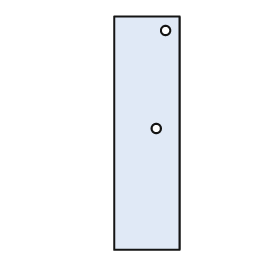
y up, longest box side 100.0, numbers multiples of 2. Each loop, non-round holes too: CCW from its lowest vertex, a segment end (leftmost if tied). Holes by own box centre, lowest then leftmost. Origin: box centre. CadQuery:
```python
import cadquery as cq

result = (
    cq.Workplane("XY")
    .moveTo(-14.0, -50.0)
    .lineTo(14.0, -50.0)
    .lineTo(14.0, 50.0)
    .lineTo(-14.0, 50.0)
    .close()
    .moveTo(4.0, 2.0)
    .circle(2.0)
    .moveTo(8.0, 44.0)
    .circle(2.0)
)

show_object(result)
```